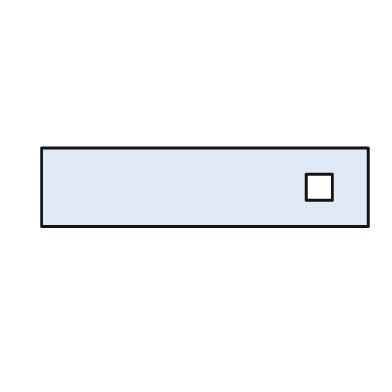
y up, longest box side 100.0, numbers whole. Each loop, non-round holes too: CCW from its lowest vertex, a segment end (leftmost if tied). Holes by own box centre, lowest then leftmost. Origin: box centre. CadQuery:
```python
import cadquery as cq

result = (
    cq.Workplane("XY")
    .moveTo(-50.0, -12.0)
    .lineTo(50.0, -12.0)
    .lineTo(50.0, 12.0)
    .lineTo(-50.0, 12.0)
    .close()
    .moveTo(31.0, -4.0)
    .lineTo(39.0, -4.0)
    .lineTo(39.0, 4.0)
    .lineTo(31.0, 4.0)
    .close()
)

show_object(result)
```